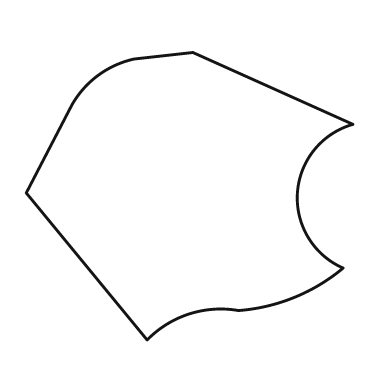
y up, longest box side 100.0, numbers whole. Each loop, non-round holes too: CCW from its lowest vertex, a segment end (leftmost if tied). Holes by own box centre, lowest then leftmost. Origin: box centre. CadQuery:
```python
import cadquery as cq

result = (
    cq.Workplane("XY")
    .moveTo(-13.0, -44.0)
    .threePointArc((0.0, -36.0), (15.0, -35.0))
    .threePointArc((32.0, -31.0), (47.0, -22.0))
    .threePointArc((33.0, 1.0), (50.0, 22.0))
    .lineTo(1.0, 44.0)
    .lineTo(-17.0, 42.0)
    .threePointArc((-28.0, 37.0), (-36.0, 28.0))
    .lineTo(-50.0, 1.0)
    .close()
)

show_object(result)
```